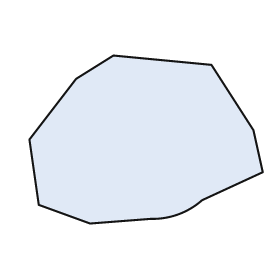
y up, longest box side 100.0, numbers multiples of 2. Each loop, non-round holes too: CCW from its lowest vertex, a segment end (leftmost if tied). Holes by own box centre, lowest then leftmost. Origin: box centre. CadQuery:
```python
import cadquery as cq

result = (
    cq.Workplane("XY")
    .moveTo(-24.0, -36.0)
    .lineTo(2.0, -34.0)
    .threePointArc((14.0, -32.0), (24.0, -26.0))
    .lineTo(50.0, -14.0)
    .lineTo(46.0, 4.0)
    .lineTo(28.0, 32.0)
    .lineTo(-14.0, 36.0)
    .lineTo(-30.0, 26.0)
    .lineTo(-50.0, 0.0)
    .lineTo(-46.0, -28.0)
    .close()
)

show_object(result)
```